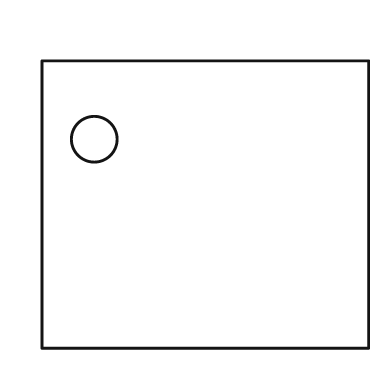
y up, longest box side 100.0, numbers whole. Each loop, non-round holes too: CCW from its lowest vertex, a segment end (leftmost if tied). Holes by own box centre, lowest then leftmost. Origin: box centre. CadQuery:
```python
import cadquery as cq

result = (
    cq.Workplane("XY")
    .moveTo(-50.0, -44.0)
    .lineTo(50.0, -44.0)
    .lineTo(50.0, 44.0)
    .lineTo(-50.0, 44.0)
    .close()
    .moveTo(-34.0, 20.0)
    .circle(7.0)
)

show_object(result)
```